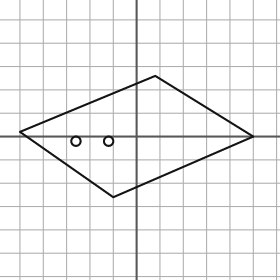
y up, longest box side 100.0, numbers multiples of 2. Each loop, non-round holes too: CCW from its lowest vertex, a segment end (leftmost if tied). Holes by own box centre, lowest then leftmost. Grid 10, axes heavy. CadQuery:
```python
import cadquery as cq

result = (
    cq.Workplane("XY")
    .moveTo(-10.0, -26.0)
    .lineTo(50.0, 0.0)
    .lineTo(8.0, 26.0)
    .lineTo(-50.0, 2.0)
    .close()
    .moveTo(-26.0, -2.0)
    .circle(2.0)
    .moveTo(-12.0, -2.0)
    .circle(2.0)
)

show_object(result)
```